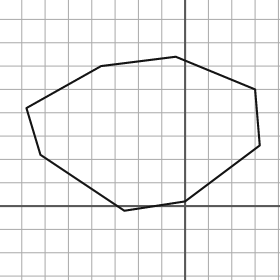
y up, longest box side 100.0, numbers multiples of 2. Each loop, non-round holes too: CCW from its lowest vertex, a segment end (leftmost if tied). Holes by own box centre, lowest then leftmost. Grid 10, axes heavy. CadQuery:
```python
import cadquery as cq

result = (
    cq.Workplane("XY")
    .moveTo(-26.0, -2.0)
    .lineTo(0.0, 2.0)
    .lineTo(32.0, 26.0)
    .lineTo(30.0, 50.0)
    .lineTo(-4.0, 64.0)
    .lineTo(-36.0, 60.0)
    .lineTo(-68.0, 42.0)
    .lineTo(-62.0, 22.0)
    .close()
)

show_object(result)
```